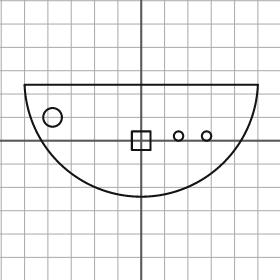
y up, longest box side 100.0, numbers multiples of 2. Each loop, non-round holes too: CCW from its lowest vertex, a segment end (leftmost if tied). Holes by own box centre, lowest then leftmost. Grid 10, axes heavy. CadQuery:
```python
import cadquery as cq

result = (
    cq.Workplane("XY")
    .moveTo(-50.0, 24.0)
    .threePointArc((0.0, -24.0), (50.0, 24.0))
    .close()
    .moveTo(-4.0, -4.0)
    .lineTo(4.0, -4.0)
    .lineTo(4.0, 4.0)
    .lineTo(-4.0, 4.0)
    .close()
    .moveTo(16.0, 2.0)
    .circle(2.0)
    .moveTo(28.0, 2.0)
    .circle(2.0)
    .moveTo(-38.0, 10.0)
    .circle(4.0)
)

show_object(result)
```